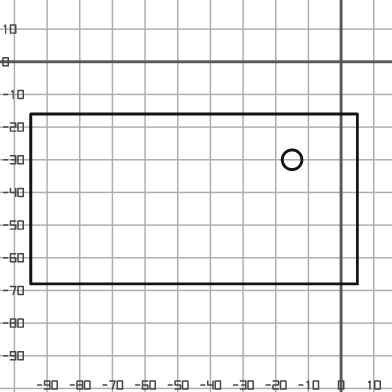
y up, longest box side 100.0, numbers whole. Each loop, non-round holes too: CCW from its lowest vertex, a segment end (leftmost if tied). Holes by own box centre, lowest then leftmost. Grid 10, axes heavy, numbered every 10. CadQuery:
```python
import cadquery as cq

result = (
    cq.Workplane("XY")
    .moveTo(-95.0, -68.0)
    .lineTo(5.0, -68.0)
    .lineTo(5.0, -16.0)
    .lineTo(-95.0, -16.0)
    .close()
    .moveTo(-15.0, -30.0)
    .circle(3.0)
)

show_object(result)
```